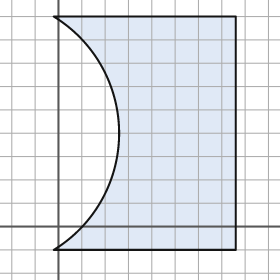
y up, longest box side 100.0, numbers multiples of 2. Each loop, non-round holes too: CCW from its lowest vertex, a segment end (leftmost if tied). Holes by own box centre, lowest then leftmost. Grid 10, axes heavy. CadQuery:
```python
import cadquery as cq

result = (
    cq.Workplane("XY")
    .moveTo(-2.0, -10.0)
    .lineTo(76.0, -10.0)
    .lineTo(76.0, 90.0)
    .lineTo(-2.0, 90.0)
    .threePointArc((26.0, 40.0), (-2.0, -10.0))
    .close()
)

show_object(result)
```